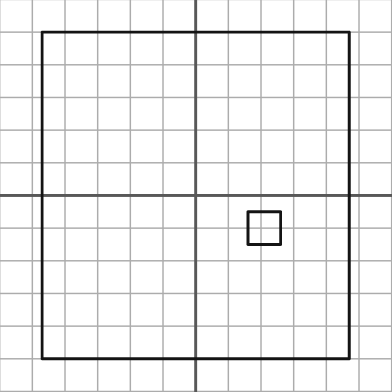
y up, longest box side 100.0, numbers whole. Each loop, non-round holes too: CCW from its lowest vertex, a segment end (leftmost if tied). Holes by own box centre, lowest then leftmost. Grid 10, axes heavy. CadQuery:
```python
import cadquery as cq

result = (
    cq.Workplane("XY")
    .moveTo(-47.0, -50.0)
    .lineTo(47.0, -50.0)
    .lineTo(47.0, 50.0)
    .lineTo(-47.0, 50.0)
    .close()
    .moveTo(16.0, -15.0)
    .lineTo(26.0, -15.0)
    .lineTo(26.0, -5.0)
    .lineTo(16.0, -5.0)
    .close()
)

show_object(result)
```